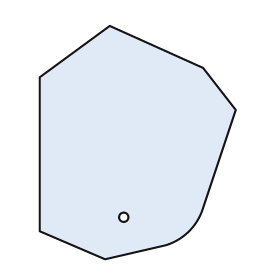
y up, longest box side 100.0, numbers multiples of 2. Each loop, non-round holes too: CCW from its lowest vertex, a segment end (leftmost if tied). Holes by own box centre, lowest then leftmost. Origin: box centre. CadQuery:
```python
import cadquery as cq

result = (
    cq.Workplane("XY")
    .moveTo(-14.0, -50.0)
    .lineTo(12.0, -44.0)
    .threePointArc((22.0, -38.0), (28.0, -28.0))
    .lineTo(42.0, 14.0)
    .lineTo(28.0, 32.0)
    .lineTo(-12.0, 50.0)
    .lineTo(-42.0, 28.0)
    .lineTo(-42.0, -38.0)
    .close()
    .moveTo(-6.0, -32.0)
    .circle(2.0)
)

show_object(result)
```